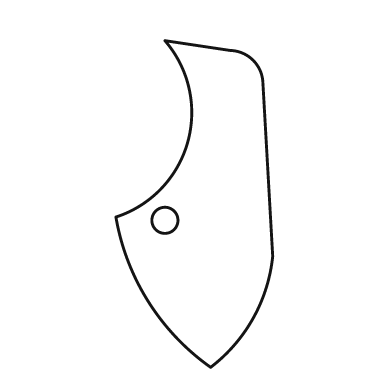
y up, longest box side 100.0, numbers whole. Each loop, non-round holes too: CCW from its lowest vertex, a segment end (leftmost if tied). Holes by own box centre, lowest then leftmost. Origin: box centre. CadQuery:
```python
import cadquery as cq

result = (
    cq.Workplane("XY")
    .moveTo(5.0, -50.0)
    .threePointArc((18.0, -35.0), (24.0, -16.0))
    .lineTo(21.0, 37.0)
    .threePointArc((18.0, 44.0), (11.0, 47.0))
    .lineTo(-9.0, 50.0)
    .threePointArc((-2.0, 19.0), (-24.0, -4.0))
    .threePointArc((-14.0, -30.0), (5.0, -50.0))
    .close()
    .moveTo(-9.0, -5.0)
    .circle(4.0)
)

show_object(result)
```